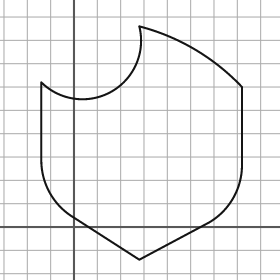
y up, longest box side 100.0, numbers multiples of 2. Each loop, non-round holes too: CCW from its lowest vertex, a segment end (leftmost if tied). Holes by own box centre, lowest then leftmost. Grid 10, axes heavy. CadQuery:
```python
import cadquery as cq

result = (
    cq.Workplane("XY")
    .moveTo(28.0, -14.0)
    .lineTo(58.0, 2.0)
    .threePointArc((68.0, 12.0), (72.0, 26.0))
    .lineTo(72.0, 60.0)
    .threePointArc((52.0, 76.0), (28.0, 86.0))
    .threePointArc((16.0, 58.0), (-14.0, 62.0))
    .lineTo(-14.0, 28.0)
    .threePointArc((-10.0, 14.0), (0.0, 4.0))
    .close()
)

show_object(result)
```